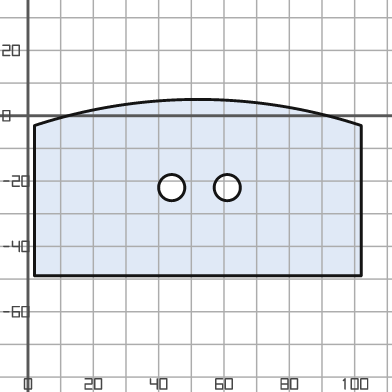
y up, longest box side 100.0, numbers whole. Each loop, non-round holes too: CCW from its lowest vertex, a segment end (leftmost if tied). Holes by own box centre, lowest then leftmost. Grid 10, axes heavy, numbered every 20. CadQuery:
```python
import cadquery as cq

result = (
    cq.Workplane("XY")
    .moveTo(2.0, -49.0)
    .lineTo(102.0, -49.0)
    .lineTo(102.0, -3.0)
    .threePointArc((52.0, 5.0), (2.0, -3.0))
    .close()
    .moveTo(44.0, -22.0)
    .circle(4.0)
    .moveTo(61.0, -22.0)
    .circle(4.0)
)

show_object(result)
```